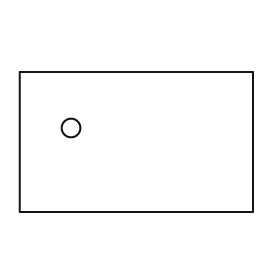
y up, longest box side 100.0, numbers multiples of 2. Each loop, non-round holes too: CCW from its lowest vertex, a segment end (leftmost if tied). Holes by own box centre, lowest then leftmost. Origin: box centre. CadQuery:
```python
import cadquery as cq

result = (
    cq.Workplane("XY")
    .moveTo(-50.0, -30.0)
    .lineTo(50.0, -30.0)
    .lineTo(50.0, 30.0)
    .lineTo(-50.0, 30.0)
    .close()
    .moveTo(-28.0, 6.0)
    .circle(4.0)
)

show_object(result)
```